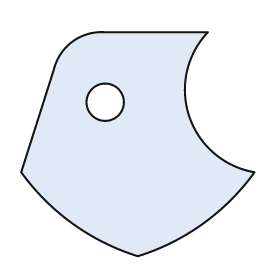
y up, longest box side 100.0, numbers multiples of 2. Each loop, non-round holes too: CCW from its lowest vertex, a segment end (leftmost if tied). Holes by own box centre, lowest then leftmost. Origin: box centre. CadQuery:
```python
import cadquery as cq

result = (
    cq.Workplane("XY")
    .moveTo(0.0, -48.0)
    .threePointArc((28.0, -34.0), (50.0, -12.0))
    .threePointArc((22.0, 12.0), (30.0, 48.0))
    .lineTo(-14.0, 48.0)
    .threePointArc((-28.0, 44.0), (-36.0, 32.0))
    .lineTo(-50.0, -12.0)
    .threePointArc((-28.0, -34.0), (0.0, -48.0))
    .close()
    .moveTo(-14.0, 18.0)
    .circle(8.0)
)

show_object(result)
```